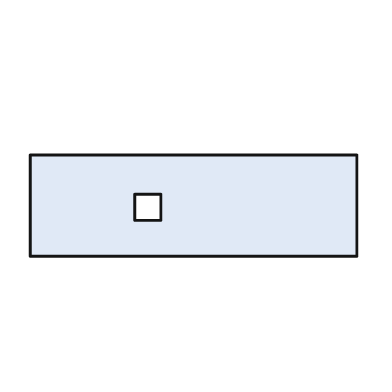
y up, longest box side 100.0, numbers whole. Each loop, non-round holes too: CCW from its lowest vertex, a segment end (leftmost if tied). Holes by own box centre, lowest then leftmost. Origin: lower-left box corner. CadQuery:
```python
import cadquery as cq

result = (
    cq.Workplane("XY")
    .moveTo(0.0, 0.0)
    .lineTo(100.0, 0.0)
    .lineTo(100.0, 31.0)
    .lineTo(0.0, 31.0)
    .close()
    .moveTo(32.0, 11.0)
    .lineTo(40.0, 11.0)
    .lineTo(40.0, 19.0)
    .lineTo(32.0, 19.0)
    .close()
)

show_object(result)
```